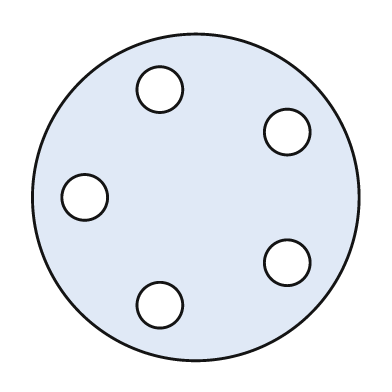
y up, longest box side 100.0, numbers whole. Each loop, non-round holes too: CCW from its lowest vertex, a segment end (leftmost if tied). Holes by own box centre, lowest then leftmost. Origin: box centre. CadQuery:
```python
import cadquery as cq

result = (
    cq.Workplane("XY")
    .moveTo(0.0, 0.0)
    .circle(50.0)
    .moveTo(-11.0, -33.0)
    .circle(7.0)
    .moveTo(28.0, -20.0)
    .circle(7.0)
    .moveTo(-34.0, 0.0)
    .circle(7.0)
    .moveTo(28.0, 20.0)
    .circle(7.0)
    .moveTo(-11.0, 33.0)
    .circle(7.0)
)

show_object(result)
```